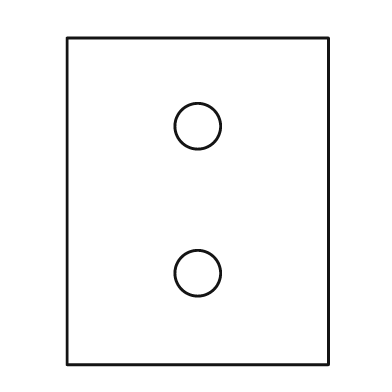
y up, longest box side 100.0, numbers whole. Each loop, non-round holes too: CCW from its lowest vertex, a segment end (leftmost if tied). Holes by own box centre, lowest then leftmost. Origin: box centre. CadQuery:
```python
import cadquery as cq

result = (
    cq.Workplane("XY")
    .moveTo(-40.0, -50.0)
    .lineTo(40.0, -50.0)
    .lineTo(40.0, 50.0)
    .lineTo(-40.0, 50.0)
    .close()
    .moveTo(0.0, -22.0)
    .circle(7.0)
    .moveTo(0.0, 23.0)
    .circle(7.0)
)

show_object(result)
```